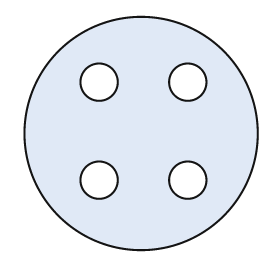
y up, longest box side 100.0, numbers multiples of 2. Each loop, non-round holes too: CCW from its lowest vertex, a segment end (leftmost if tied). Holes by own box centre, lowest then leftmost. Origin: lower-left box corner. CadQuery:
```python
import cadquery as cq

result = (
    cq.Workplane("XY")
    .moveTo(50.0, 50.0)
    .circle(50.0)
    .moveTo(32.0, 30.0)
    .circle(8.0)
    .moveTo(70.0, 30.0)
    .circle(8.0)
    .moveTo(32.0, 72.0)
    .circle(8.0)
    .moveTo(70.0, 72.0)
    .circle(8.0)
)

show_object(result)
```